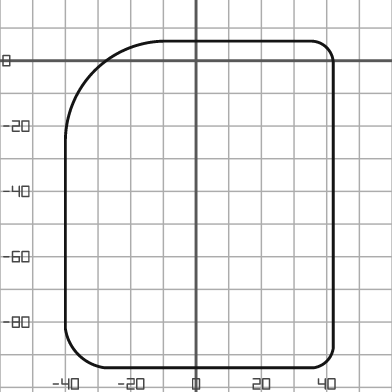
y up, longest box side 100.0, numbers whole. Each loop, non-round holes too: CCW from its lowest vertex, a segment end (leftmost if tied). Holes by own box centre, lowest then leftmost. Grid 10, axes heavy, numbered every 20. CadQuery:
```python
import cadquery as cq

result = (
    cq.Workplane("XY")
    .moveTo(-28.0, -94.0)
    .lineTo(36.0, -94.0)
    .threePointArc((40.0, -92.0), (42.0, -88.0))
    .lineTo(42.0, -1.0)
    .threePointArc((40.0, 4.0), (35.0, 6.0))
    .lineTo(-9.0, 6.0)
    .threePointArc((-31.0, -3.0), (-40.0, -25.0))
    .lineTo(-40.0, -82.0)
    .threePointArc((-36.0, -90.0), (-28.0, -94.0))
    .close()
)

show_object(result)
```